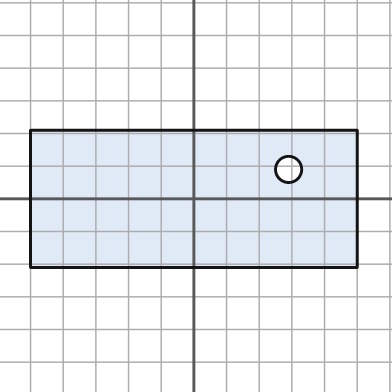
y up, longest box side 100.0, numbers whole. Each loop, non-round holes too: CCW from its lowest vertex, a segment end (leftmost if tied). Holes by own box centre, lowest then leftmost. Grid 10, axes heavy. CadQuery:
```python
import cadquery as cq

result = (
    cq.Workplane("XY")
    .moveTo(-50.0, -21.0)
    .lineTo(50.0, -21.0)
    .lineTo(50.0, 21.0)
    .lineTo(-50.0, 21.0)
    .close()
    .moveTo(29.0, 9.0)
    .circle(4.0)
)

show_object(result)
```